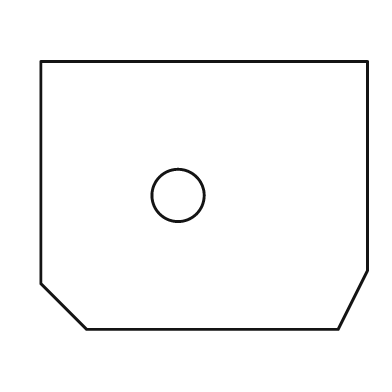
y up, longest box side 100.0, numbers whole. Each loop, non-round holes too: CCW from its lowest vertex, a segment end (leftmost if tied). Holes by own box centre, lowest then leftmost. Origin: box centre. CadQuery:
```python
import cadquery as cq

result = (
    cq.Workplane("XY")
    .moveTo(-36.0, -41.0)
    .lineTo(41.0, -41.0)
    .lineTo(50.0, -23.0)
    .lineTo(50.0, 41.0)
    .lineTo(-50.0, 41.0)
    .lineTo(-50.0, -27.0)
    .close()
    .moveTo(-8.0, 0.0)
    .circle(8.0)
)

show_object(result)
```